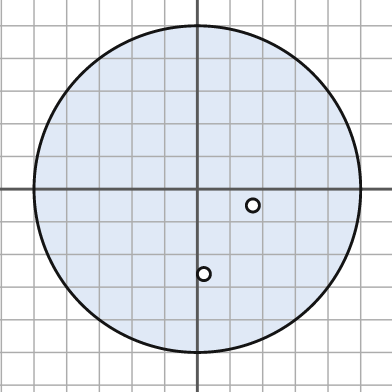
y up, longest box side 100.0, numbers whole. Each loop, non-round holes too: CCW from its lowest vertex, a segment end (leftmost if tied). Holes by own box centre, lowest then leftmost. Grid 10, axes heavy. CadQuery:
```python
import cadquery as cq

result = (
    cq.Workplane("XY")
    .moveTo(0.0, 0.0)
    .circle(50.0)
    .moveTo(2.0, -26.0)
    .circle(2.0)
    .moveTo(17.0, -5.0)
    .circle(2.0)
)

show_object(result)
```